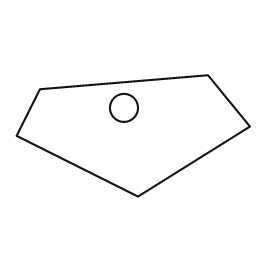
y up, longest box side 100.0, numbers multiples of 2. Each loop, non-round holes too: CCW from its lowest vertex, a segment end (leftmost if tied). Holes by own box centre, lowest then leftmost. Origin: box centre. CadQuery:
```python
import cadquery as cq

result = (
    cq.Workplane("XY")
    .moveTo(2.0, -26.0)
    .lineTo(50.0, 4.0)
    .lineTo(32.0, 26.0)
    .lineTo(-40.0, 20.0)
    .lineTo(-50.0, 0.0)
    .close()
    .moveTo(-4.0, 12.0)
    .circle(6.0)
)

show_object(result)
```